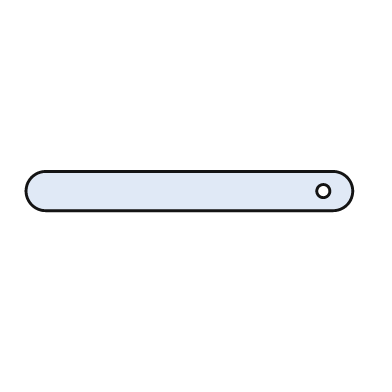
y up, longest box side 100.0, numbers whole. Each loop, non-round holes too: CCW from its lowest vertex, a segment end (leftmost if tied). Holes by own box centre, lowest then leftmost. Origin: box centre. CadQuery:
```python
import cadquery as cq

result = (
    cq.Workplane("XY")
    .moveTo(-44.0, -6.0)
    .lineTo(44.0, -6.0)
    .threePointArc((50.0, 0.0), (44.0, 6.0))
    .lineTo(-44.0, 6.0)
    .threePointArc((-50.0, 0.0), (-44.0, -6.0))
    .close()
    .moveTo(41.0, 0.0)
    .circle(2.0)
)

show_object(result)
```